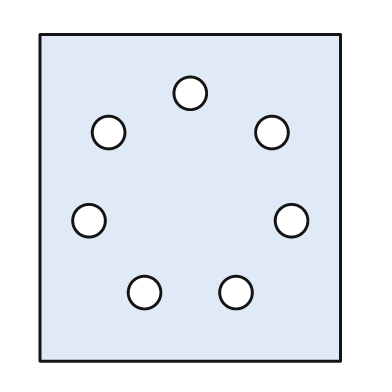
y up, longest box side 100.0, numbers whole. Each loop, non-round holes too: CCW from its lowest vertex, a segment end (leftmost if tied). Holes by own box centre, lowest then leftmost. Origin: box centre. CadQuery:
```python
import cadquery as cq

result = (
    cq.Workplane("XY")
    .moveTo(-46.0, -50.0)
    .lineTo(46.0, -50.0)
    .lineTo(46.0, 50.0)
    .lineTo(-46.0, 50.0)
    .close()
    .moveTo(-14.0, -29.0)
    .circle(5.0)
    .moveTo(14.0, -29.0)
    .circle(5.0)
    .moveTo(-31.0, -7.0)
    .circle(5.0)
    .moveTo(31.0, -7.0)
    .circle(5.0)
    .moveTo(-25.0, 20.0)
    .circle(5.0)
    .moveTo(25.0, 20.0)
    .circle(5.0)
    .moveTo(0.0, 32.0)
    .circle(5.0)
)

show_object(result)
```